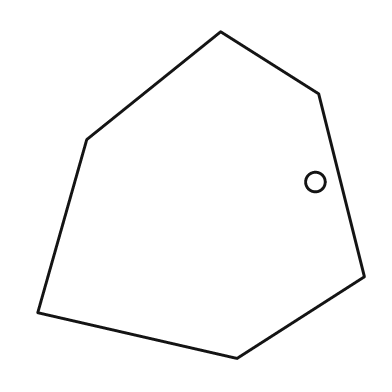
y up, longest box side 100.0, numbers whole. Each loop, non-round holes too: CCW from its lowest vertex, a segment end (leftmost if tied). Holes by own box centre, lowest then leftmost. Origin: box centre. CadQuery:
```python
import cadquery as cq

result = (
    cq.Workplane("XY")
    .moveTo(11.0, -50.0)
    .lineTo(50.0, -25.0)
    .lineTo(36.0, 31.0)
    .lineTo(6.0, 50.0)
    .lineTo(-35.0, 17.0)
    .lineTo(-50.0, -36.0)
    .close()
    .moveTo(35.0, 4.0)
    .circle(3.0)
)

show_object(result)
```